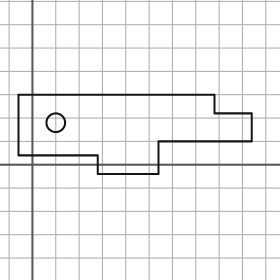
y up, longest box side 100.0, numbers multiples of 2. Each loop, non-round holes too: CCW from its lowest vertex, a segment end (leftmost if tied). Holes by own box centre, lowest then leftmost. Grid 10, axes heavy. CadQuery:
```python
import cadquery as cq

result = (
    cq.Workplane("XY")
    .moveTo(28.0, -4.0)
    .lineTo(54.0, -4.0)
    .lineTo(54.0, 10.0)
    .lineTo(94.0, 10.0)
    .lineTo(94.0, 22.0)
    .lineTo(78.0, 22.0)
    .lineTo(78.0, 30.0)
    .lineTo(-6.0, 30.0)
    .lineTo(-6.0, 4.0)
    .lineTo(28.0, 4.0)
    .close()
    .moveTo(10.0, 18.0)
    .circle(4.0)
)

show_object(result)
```